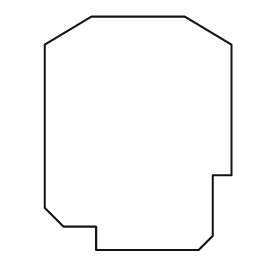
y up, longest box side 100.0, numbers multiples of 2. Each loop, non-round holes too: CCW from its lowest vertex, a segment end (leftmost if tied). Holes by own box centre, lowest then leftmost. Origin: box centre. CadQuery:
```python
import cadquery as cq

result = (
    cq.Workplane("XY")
    .moveTo(-18.0, -50.0)
    .lineTo(26.0, -50.0)
    .lineTo(32.0, -44.0)
    .lineTo(32.0, -18.0)
    .lineTo(40.0, -18.0)
    .lineTo(40.0, 38.0)
    .lineTo(20.0, 50.0)
    .lineTo(-20.0, 50.0)
    .lineTo(-40.0, 38.0)
    .lineTo(-40.0, -32.0)
    .lineTo(-32.0, -40.0)
    .lineTo(-18.0, -40.0)
    .close()
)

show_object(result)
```